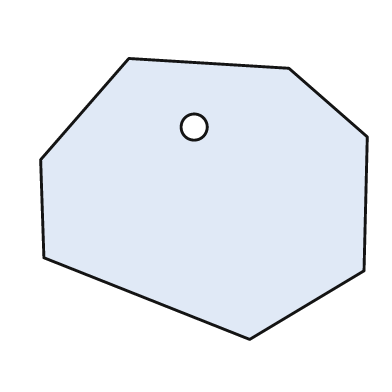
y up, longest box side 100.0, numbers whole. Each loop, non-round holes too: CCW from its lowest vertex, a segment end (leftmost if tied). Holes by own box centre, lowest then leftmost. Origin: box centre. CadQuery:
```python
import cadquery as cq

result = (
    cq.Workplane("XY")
    .moveTo(14.0, -43.0)
    .lineTo(49.0, -22.0)
    .lineTo(50.0, 19.0)
    .lineTo(26.0, 40.0)
    .lineTo(-23.0, 43.0)
    .lineTo(-50.0, 12.0)
    .lineTo(-49.0, -18.0)
    .close()
    .moveTo(-3.0, 22.0)
    .circle(4.0)
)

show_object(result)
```